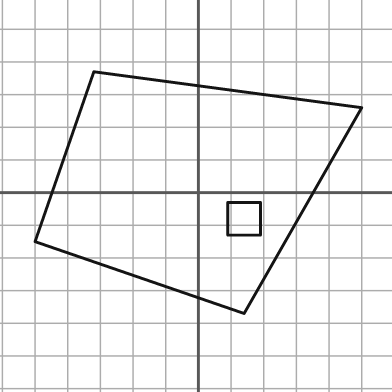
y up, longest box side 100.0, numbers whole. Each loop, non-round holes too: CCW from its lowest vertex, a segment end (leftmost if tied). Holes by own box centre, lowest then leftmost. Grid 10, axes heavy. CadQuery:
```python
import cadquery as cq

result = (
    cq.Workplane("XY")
    .moveTo(14.0, -37.0)
    .lineTo(50.0, 26.0)
    .lineTo(-32.0, 37.0)
    .lineTo(-50.0, -15.0)
    .close()
    .moveTo(9.0, -13.0)
    .lineTo(19.0, -13.0)
    .lineTo(19.0, -3.0)
    .lineTo(9.0, -3.0)
    .close()
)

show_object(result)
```